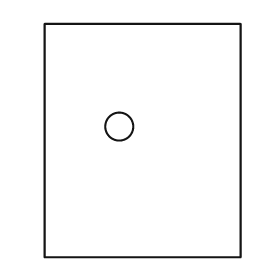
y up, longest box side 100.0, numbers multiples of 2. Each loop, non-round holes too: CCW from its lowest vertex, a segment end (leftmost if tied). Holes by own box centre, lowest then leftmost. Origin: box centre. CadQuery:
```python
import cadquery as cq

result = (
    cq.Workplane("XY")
    .moveTo(-42.0, -50.0)
    .lineTo(42.0, -50.0)
    .lineTo(42.0, 50.0)
    .lineTo(-42.0, 50.0)
    .close()
    .moveTo(-10.0, 6.0)
    .circle(6.0)
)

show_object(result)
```